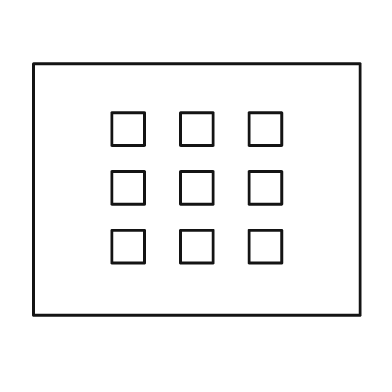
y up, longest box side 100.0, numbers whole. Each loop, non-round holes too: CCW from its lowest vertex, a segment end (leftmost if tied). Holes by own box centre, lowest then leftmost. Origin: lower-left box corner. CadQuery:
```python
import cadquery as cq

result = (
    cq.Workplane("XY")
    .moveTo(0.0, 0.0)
    .lineTo(100.0, 0.0)
    .lineTo(100.0, 77.0)
    .lineTo(0.0, 77.0)
    .close()
    .moveTo(24.0, 16.0)
    .lineTo(34.0, 16.0)
    .lineTo(34.0, 26.0)
    .lineTo(24.0, 26.0)
    .close()
    .moveTo(45.0, 16.0)
    .lineTo(55.0, 16.0)
    .lineTo(55.0, 26.0)
    .lineTo(45.0, 26.0)
    .close()
    .moveTo(66.0, 16.0)
    .lineTo(76.0, 16.0)
    .lineTo(76.0, 26.0)
    .lineTo(66.0, 26.0)
    .close()
    .moveTo(24.0, 34.0)
    .lineTo(34.0, 34.0)
    .lineTo(34.0, 44.0)
    .lineTo(24.0, 44.0)
    .close()
    .moveTo(45.0, 34.0)
    .lineTo(55.0, 34.0)
    .lineTo(55.0, 44.0)
    .lineTo(45.0, 44.0)
    .close()
    .moveTo(66.0, 34.0)
    .lineTo(76.0, 34.0)
    .lineTo(76.0, 44.0)
    .lineTo(66.0, 44.0)
    .close()
    .moveTo(24.0, 52.0)
    .lineTo(34.0, 52.0)
    .lineTo(34.0, 62.0)
    .lineTo(24.0, 62.0)
    .close()
    .moveTo(45.0, 52.0)
    .lineTo(55.0, 52.0)
    .lineTo(55.0, 62.0)
    .lineTo(45.0, 62.0)
    .close()
    .moveTo(66.0, 52.0)
    .lineTo(76.0, 52.0)
    .lineTo(76.0, 62.0)
    .lineTo(66.0, 62.0)
    .close()
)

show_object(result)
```